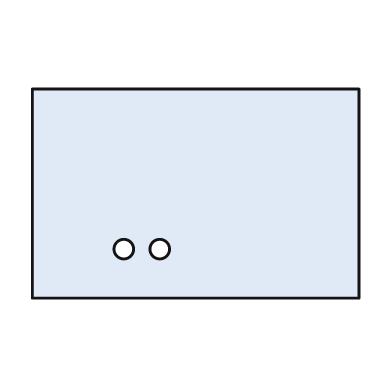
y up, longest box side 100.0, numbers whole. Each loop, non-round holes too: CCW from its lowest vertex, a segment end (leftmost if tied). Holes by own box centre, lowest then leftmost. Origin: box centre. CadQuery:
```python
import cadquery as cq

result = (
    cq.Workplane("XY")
    .moveTo(-50.0, -32.0)
    .lineTo(50.0, -32.0)
    .lineTo(50.0, 32.0)
    .lineTo(-50.0, 32.0)
    .close()
    .moveTo(-22.0, -17.0)
    .circle(3.0)
    .moveTo(-11.0, -17.0)
    .circle(3.0)
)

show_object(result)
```